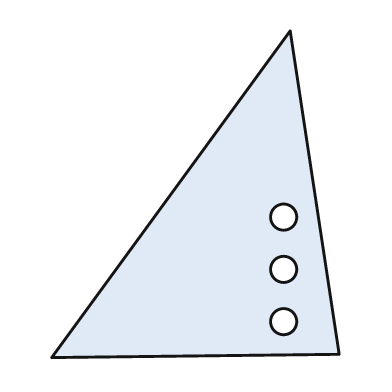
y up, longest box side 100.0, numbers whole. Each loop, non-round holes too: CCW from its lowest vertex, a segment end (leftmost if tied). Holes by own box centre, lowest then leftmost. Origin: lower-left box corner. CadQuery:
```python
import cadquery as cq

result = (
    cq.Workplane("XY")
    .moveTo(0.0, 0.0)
    .lineTo(88.0, 1.0)
    .lineTo(73.0, 100.0)
    .close()
    .moveTo(71.0, 11.0)
    .circle(4.0)
    .moveTo(71.0, 27.0)
    .circle(4.0)
    .moveTo(71.0, 43.0)
    .circle(4.0)
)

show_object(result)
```